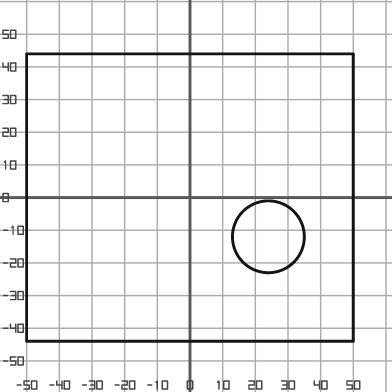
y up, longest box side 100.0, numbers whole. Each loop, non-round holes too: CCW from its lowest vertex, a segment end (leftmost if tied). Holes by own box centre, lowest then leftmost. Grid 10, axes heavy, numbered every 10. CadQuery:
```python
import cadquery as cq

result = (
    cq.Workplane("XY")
    .moveTo(-50.0, -44.0)
    .lineTo(50.0, -44.0)
    .lineTo(50.0, 44.0)
    .lineTo(-50.0, 44.0)
    .close()
    .moveTo(24.0, -12.0)
    .circle(11.0)
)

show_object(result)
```